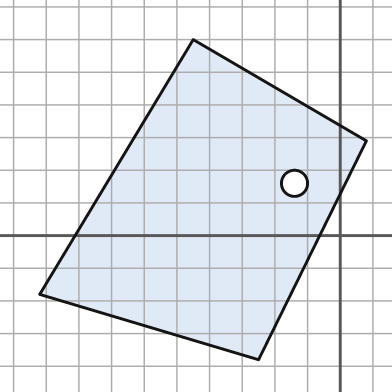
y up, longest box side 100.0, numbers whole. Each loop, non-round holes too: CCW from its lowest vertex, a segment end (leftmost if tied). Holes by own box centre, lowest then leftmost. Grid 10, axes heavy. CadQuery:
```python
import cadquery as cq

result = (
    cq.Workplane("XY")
    .moveTo(-25.0, -38.0)
    .lineTo(8.0, 29.0)
    .lineTo(-45.0, 60.0)
    .lineTo(-92.0, -18.0)
    .close()
    .moveTo(-14.0, 16.0)
    .circle(4.0)
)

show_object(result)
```